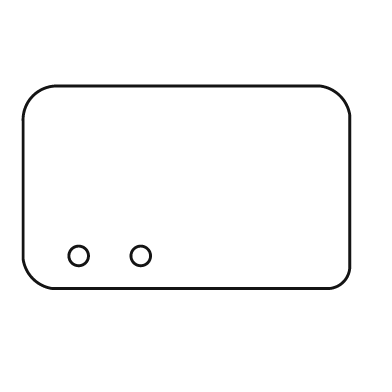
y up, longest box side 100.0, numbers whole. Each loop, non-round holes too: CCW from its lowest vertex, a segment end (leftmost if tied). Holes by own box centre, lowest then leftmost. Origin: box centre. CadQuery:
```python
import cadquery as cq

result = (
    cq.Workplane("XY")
    .moveTo(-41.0, -31.0)
    .lineTo(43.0, -31.0)
    .threePointArc((48.0, -29.0), (50.0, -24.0))
    .lineTo(50.0, 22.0)
    .threePointArc((47.0, 28.0), (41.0, 31.0))
    .lineTo(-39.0, 31.0)
    .threePointArc((-47.0, 28.0), (-50.0, 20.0))
    .lineTo(-50.0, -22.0)
    .threePointArc((-47.0, -28.0), (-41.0, -31.0))
    .close()
    .moveTo(-33.0, -21.0)
    .circle(3.0)
    .moveTo(-14.0, -21.0)
    .circle(3.0)
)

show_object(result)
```